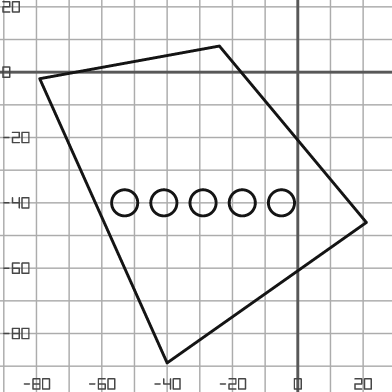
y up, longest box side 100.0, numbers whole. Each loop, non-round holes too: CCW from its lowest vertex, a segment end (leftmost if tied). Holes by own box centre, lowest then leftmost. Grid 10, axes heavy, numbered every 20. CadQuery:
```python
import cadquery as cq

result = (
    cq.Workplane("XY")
    .moveTo(-40.0, -89.0)
    .lineTo(21.0, -46.0)
    .lineTo(-24.0, 8.0)
    .lineTo(-79.0, -2.0)
    .close()
    .moveTo(-53.0, -40.0)
    .circle(4.0)
    .moveTo(-41.0, -40.0)
    .circle(4.0)
    .moveTo(-29.0, -40.0)
    .circle(4.0)
    .moveTo(-17.0, -40.0)
    .circle(4.0)
    .moveTo(-5.0, -40.0)
    .circle(4.0)
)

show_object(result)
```